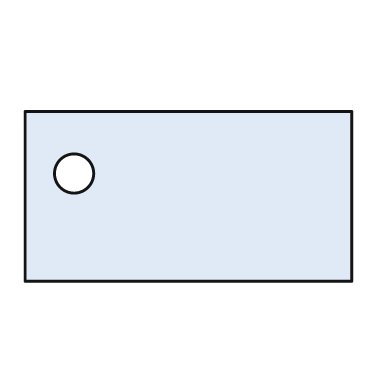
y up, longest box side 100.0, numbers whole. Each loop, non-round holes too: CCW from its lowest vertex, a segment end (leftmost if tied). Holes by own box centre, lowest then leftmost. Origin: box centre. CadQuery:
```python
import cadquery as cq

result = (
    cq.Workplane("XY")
    .moveTo(-50.0, -26.0)
    .lineTo(50.0, -26.0)
    .lineTo(50.0, 26.0)
    .lineTo(-50.0, 26.0)
    .close()
    .moveTo(-35.0, 7.0)
    .circle(6.0)
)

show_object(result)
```